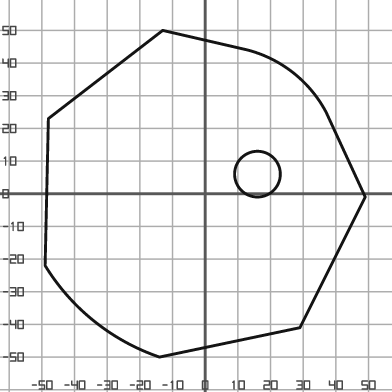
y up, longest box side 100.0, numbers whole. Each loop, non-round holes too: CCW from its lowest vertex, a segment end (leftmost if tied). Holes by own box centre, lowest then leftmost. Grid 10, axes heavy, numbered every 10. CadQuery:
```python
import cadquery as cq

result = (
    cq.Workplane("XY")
    .moveTo(-14.0, -50.0)
    .lineTo(29.0, -41.0)
    .lineTo(49.0, -1.0)
    .lineTo(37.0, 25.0)
    .threePointArc((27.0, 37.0), (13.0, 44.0))
    .lineTo(-13.0, 50.0)
    .lineTo(-48.0, 23.0)
    .lineTo(-49.0, -22.0)
    .threePointArc((-34.0, -39.0), (-14.0, -50.0))
    .close()
    .moveTo(16.0, 6.0)
    .circle(7.0)
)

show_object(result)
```